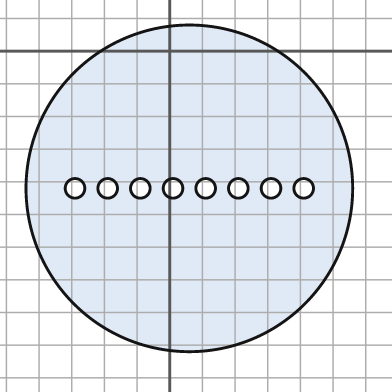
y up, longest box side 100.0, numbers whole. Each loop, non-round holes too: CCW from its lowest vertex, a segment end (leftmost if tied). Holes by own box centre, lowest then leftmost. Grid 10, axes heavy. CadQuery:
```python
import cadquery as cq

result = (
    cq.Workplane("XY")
    .moveTo(6.0, -42.0)
    .circle(50.0)
    .moveTo(-29.0, -42.0)
    .circle(3.0)
    .moveTo(-19.0, -42.0)
    .circle(3.0)
    .moveTo(-9.0, -42.0)
    .circle(3.0)
    .moveTo(1.0, -42.0)
    .circle(3.0)
    .moveTo(11.0, -42.0)
    .circle(3.0)
    .moveTo(21.0, -42.0)
    .circle(3.0)
    .moveTo(31.0, -42.0)
    .circle(3.0)
    .moveTo(41.0, -42.0)
    .circle(3.0)
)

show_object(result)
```